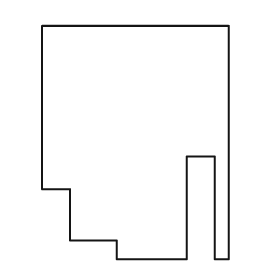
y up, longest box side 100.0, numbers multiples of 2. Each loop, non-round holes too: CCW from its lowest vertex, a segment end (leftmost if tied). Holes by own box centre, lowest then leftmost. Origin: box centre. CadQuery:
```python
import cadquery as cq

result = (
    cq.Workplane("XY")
    .moveTo(-8.0, -50.0)
    .lineTo(22.0, -50.0)
    .lineTo(22.0, -6.0)
    .lineTo(34.0, -6.0)
    .lineTo(34.0, -50.0)
    .lineTo(40.0, -50.0)
    .lineTo(40.0, 50.0)
    .lineTo(-40.0, 50.0)
    .lineTo(-40.0, -20.0)
    .lineTo(-28.0, -20.0)
    .lineTo(-28.0, -42.0)
    .lineTo(-8.0, -42.0)
    .close()
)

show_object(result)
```